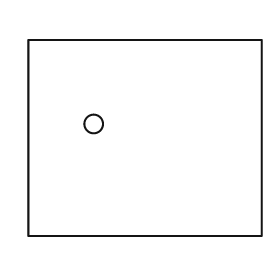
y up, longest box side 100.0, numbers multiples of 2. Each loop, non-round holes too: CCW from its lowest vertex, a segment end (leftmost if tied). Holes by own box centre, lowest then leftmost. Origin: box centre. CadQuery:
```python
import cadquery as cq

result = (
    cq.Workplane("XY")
    .moveTo(-50.0, -42.0)
    .lineTo(50.0, -42.0)
    .lineTo(50.0, 42.0)
    .lineTo(-50.0, 42.0)
    .close()
    .moveTo(-22.0, 6.0)
    .circle(4.0)
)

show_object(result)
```